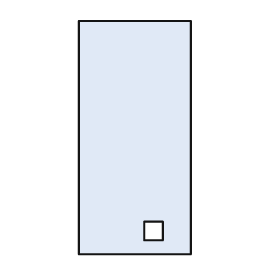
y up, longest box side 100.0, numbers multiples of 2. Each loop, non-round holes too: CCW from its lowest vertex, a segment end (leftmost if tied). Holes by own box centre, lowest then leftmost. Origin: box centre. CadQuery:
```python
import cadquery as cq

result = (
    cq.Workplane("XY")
    .moveTo(-24.0, -50.0)
    .lineTo(24.0, -50.0)
    .lineTo(24.0, 50.0)
    .lineTo(-24.0, 50.0)
    .close()
    .moveTo(4.0, -44.0)
    .lineTo(12.0, -44.0)
    .lineTo(12.0, -36.0)
    .lineTo(4.0, -36.0)
    .close()
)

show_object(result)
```